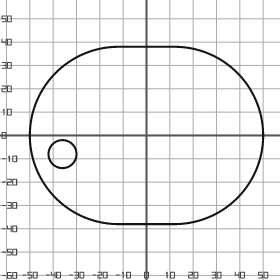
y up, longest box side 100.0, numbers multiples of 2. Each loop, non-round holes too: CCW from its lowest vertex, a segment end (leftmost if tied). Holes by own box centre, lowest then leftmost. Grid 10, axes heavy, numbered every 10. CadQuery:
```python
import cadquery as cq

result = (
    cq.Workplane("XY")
    .moveTo(-12.0, -38.0)
    .lineTo(12.0, -38.0)
    .threePointArc((50.0, 0.0), (12.0, 38.0))
    .lineTo(-12.0, 38.0)
    .threePointArc((-50.0, 0.0), (-12.0, -38.0))
    .close()
    .moveTo(-36.0, -8.0)
    .circle(6.0)
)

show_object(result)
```